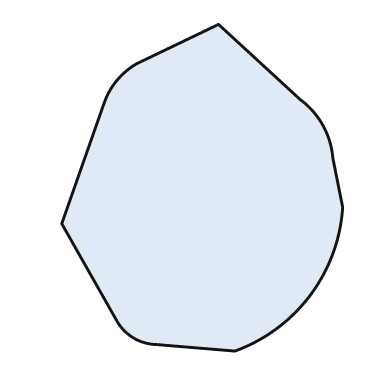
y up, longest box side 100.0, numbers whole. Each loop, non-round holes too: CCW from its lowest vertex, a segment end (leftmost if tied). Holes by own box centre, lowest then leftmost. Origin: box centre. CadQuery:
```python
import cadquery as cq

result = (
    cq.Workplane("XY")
    .moveTo(10.0, -50.0)
    .threePointArc((33.0, -33.0), (43.0, -6.0))
    .lineTo(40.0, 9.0)
    .threePointArc((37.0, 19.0), (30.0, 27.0))
    .lineTo(5.0, 50.0)
    .lineTo(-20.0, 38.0)
    .threePointArc((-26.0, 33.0), (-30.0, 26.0))
    .lineTo(-43.0, -11.0)
    .lineTo(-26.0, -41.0)
    .threePointArc((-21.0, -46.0), (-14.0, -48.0))
    .close()
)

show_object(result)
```